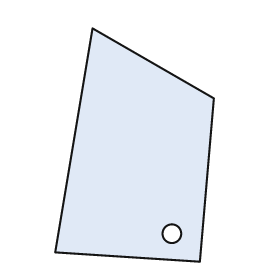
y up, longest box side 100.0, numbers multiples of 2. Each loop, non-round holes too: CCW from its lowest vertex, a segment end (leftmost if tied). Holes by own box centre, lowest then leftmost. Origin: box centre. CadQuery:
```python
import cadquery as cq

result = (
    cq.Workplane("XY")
    .moveTo(28.0, -50.0)
    .lineTo(34.0, 20.0)
    .lineTo(-18.0, 50.0)
    .lineTo(-34.0, -46.0)
    .close()
    .moveTo(16.0, -38.0)
    .circle(4.0)
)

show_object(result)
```